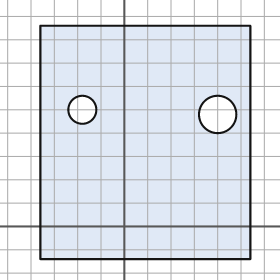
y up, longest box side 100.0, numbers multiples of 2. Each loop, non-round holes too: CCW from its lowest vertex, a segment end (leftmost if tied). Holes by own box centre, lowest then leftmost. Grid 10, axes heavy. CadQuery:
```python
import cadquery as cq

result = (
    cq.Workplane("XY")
    .moveTo(-36.0, -14.0)
    .lineTo(54.0, -14.0)
    .lineTo(54.0, 86.0)
    .lineTo(-36.0, 86.0)
    .close()
    .moveTo(40.0, 48.0)
    .circle(8.0)
    .moveTo(-18.0, 50.0)
    .circle(6.0)
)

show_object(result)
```